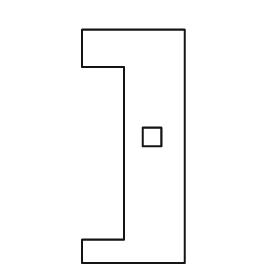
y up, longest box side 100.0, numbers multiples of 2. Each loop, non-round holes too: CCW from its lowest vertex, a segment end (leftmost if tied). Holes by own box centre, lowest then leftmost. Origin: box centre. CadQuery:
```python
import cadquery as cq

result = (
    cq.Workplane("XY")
    .moveTo(-22.0, -50.0)
    .lineTo(22.0, -50.0)
    .lineTo(22.0, 50.0)
    .lineTo(-22.0, 50.0)
    .lineTo(-22.0, 34.0)
    .lineTo(-4.0, 34.0)
    .lineTo(-4.0, -40.0)
    .lineTo(-22.0, -40.0)
    .close()
    .moveTo(4.0, 0.0)
    .lineTo(12.0, 0.0)
    .lineTo(12.0, 8.0)
    .lineTo(4.0, 8.0)
    .close()
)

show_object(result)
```